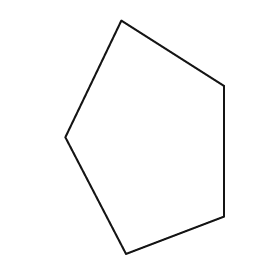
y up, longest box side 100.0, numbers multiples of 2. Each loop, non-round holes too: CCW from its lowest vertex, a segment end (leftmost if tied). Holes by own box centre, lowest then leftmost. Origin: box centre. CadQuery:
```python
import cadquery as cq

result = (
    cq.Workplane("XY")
    .moveTo(-8.0, -50.0)
    .lineTo(34.0, -34.0)
    .lineTo(34.0, 22.0)
    .lineTo(-10.0, 50.0)
    .lineTo(-34.0, 0.0)
    .close()
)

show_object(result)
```